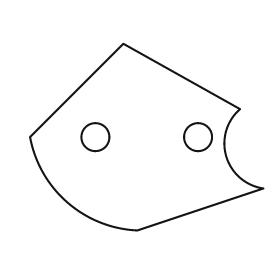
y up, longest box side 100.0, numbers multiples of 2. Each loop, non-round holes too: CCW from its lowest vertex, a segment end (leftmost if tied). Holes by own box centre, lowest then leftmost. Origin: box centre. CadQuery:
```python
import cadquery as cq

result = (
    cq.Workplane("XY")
    .moveTo(-4.0, -40.0)
    .lineTo(50.0, -22.0)
    .threePointArc((34.0, -8.0), (40.0, 12.0))
    .lineTo(-10.0, 40.0)
    .lineTo(-50.0, 0.0)
    .threePointArc((-34.0, -28.0), (-4.0, -40.0))
    .close()
    .moveTo(-22.0, 0.0)
    .circle(6.0)
    .moveTo(22.0, 0.0)
    .circle(6.0)
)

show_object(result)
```